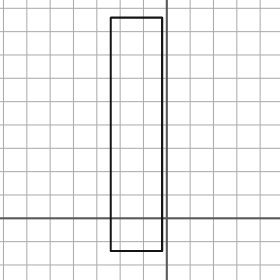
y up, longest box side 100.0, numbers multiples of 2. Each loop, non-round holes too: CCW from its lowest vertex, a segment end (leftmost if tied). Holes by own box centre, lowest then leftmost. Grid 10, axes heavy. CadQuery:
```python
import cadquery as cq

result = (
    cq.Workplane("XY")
    .moveTo(-24.0, -14.0)
    .lineTo(-2.0, -14.0)
    .lineTo(-2.0, 86.0)
    .lineTo(-24.0, 86.0)
    .close()
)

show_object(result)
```